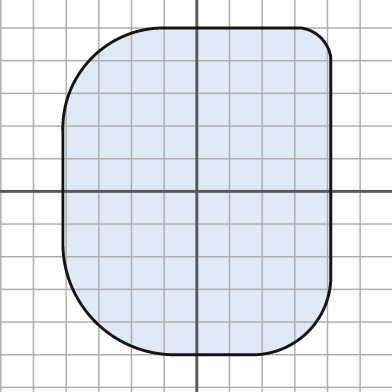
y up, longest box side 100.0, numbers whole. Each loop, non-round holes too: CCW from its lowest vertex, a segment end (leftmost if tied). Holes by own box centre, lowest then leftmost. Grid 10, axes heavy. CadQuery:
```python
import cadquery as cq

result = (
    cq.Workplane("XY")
    .moveTo(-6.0, -50.0)
    .lineTo(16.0, -50.0)
    .threePointArc((34.0, -43.0), (41.0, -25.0))
    .lineTo(41.0, 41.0)
    .threePointArc((38.0, 47.0), (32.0, 50.0))
    .lineTo(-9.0, 50.0)
    .threePointArc((-32.0, 41.0), (-41.0, 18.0))
    .lineTo(-41.0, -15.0)
    .threePointArc((-31.0, -40.0), (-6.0, -50.0))
    .close()
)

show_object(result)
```